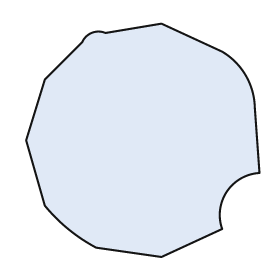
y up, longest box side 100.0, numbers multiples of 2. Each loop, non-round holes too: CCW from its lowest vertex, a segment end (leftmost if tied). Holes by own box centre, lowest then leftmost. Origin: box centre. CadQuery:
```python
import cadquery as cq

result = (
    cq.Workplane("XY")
    .moveTo(8.0, -50.0)
    .lineTo(34.0, -38.0)
    .threePointArc((36.0, -22.0), (50.0, -14.0))
    .lineTo(48.0, 14.0)
    .threePointArc((44.0, 28.0), (34.0, 38.0))
    .lineTo(8.0, 50.0)
    .lineTo(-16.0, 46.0)
    .threePointArc((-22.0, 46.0), (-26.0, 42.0))
    .lineTo(-42.0, 26.0)
    .lineTo(-50.0, 0.0)
    .lineTo(-42.0, -28.0)
    .threePointArc((-32.0, -38.0), (-20.0, -46.0))
    .close()
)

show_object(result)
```